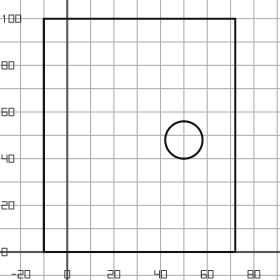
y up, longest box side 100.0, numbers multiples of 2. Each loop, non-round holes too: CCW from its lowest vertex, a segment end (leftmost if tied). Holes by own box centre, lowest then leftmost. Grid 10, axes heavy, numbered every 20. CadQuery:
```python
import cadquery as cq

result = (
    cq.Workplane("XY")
    .moveTo(-10.0, 0.0)
    .lineTo(72.0, 0.0)
    .lineTo(72.0, 100.0)
    .lineTo(-10.0, 100.0)
    .close()
    .moveTo(50.0, 48.0)
    .circle(8.0)
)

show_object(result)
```